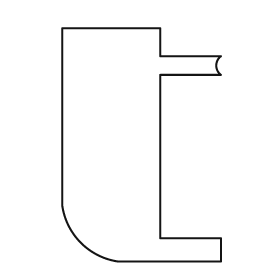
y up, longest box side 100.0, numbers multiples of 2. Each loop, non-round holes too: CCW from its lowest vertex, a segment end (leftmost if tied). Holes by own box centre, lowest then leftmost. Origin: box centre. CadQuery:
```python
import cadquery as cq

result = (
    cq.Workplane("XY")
    .moveTo(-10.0, -50.0)
    .lineTo(34.0, -50.0)
    .lineTo(34.0, -40.0)
    .lineTo(8.0, -40.0)
    .lineTo(8.0, 30.0)
    .lineTo(34.0, 30.0)
    .threePointArc((32.0, 34.0), (34.0, 38.0))
    .lineTo(8.0, 38.0)
    .lineTo(8.0, 50.0)
    .lineTo(-34.0, 50.0)
    .lineTo(-34.0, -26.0)
    .threePointArc((-26.0, -42.0), (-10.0, -50.0))
    .close()
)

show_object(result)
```